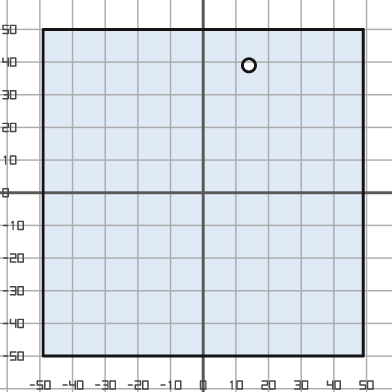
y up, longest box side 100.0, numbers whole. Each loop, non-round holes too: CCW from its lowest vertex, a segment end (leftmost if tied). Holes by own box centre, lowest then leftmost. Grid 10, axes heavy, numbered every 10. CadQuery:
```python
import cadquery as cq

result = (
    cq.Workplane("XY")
    .moveTo(-49.0, -50.0)
    .lineTo(49.0, -50.0)
    .lineTo(49.0, 50.0)
    .lineTo(-49.0, 50.0)
    .close()
    .moveTo(14.0, 39.0)
    .circle(2.0)
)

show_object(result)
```